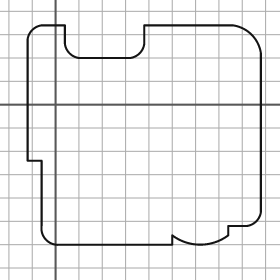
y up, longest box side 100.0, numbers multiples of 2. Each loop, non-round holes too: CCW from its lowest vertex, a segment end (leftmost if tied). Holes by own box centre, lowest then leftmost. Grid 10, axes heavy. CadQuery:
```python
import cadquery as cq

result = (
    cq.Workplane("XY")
    .moveTo(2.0, -60.0)
    .lineTo(50.0, -60.0)
    .lineTo(50.0, -56.0)
    .threePointArc((62.0, -60.0), (74.0, -56.0))
    .lineTo(74.0, -52.0)
    .lineTo(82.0, -52.0)
    .threePointArc((86.0, -50.0), (88.0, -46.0))
    .lineTo(88.0, 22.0)
    .threePointArc((84.0, 30.0), (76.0, 34.0))
    .lineTo(38.0, 34.0)
    .lineTo(38.0, 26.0)
    .threePointArc((36.0, 22.0), (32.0, 20.0))
    .lineTo(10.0, 20.0)
    .threePointArc((6.0, 22.0), (4.0, 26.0))
    .lineTo(4.0, 34.0)
    .lineTo(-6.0, 34.0)
    .threePointArc((-10.0, 32.0), (-12.0, 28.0))
    .lineTo(-12.0, -24.0)
    .lineTo(-6.0, -24.0)
    .lineTo(-6.0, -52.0)
    .threePointArc((-4.0, -58.0), (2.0, -60.0))
    .close()
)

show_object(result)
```